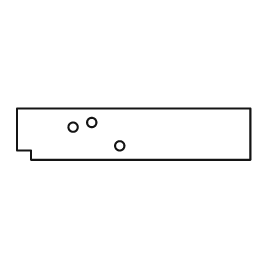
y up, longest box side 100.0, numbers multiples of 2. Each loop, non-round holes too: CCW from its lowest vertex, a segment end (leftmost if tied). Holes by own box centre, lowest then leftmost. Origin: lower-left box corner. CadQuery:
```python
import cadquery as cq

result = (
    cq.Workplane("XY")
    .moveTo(6.0, 0.0)
    .lineTo(100.0, 0.0)
    .lineTo(100.0, 22.0)
    .lineTo(0.0, 22.0)
    .lineTo(0.0, 4.0)
    .lineTo(6.0, 4.0)
    .close()
    .moveTo(44.0, 6.0)
    .circle(2.0)
    .moveTo(24.0, 14.0)
    .circle(2.0)
    .moveTo(32.0, 16.0)
    .circle(2.0)
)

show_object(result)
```